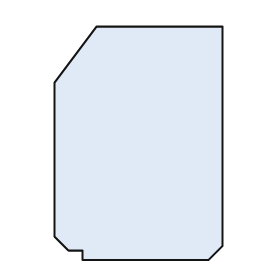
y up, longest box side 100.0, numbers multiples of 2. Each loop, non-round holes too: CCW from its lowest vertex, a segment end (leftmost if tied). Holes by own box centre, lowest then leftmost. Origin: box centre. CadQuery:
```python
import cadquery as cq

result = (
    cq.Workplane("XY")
    .moveTo(-24.0, -50.0)
    .lineTo(30.0, -50.0)
    .lineTo(36.0, -44.0)
    .lineTo(36.0, 50.0)
    .lineTo(-18.0, 50.0)
    .lineTo(-36.0, 26.0)
    .lineTo(-36.0, -40.0)
    .lineTo(-30.0, -46.0)
    .lineTo(-24.0, -46.0)
    .close()
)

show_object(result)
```